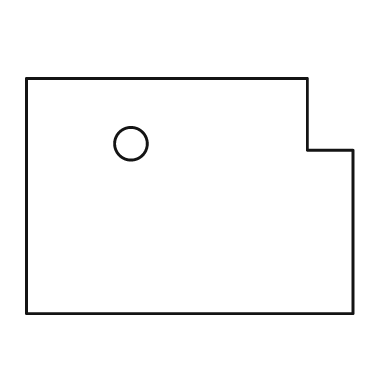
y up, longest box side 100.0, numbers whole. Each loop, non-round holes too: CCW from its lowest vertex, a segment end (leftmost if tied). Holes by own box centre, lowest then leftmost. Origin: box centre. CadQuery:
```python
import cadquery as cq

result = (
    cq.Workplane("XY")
    .moveTo(-50.0, -36.0)
    .lineTo(50.0, -36.0)
    .lineTo(50.0, 14.0)
    .lineTo(36.0, 14.0)
    .lineTo(36.0, 36.0)
    .lineTo(-50.0, 36.0)
    .close()
    .moveTo(-18.0, 16.0)
    .circle(5.0)
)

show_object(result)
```